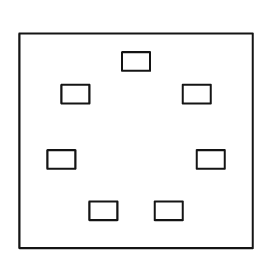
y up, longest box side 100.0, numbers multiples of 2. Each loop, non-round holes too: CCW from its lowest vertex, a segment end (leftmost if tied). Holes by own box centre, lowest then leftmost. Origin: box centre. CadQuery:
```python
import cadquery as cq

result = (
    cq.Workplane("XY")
    .moveTo(-50.0, -46.0)
    .lineTo(50.0, -46.0)
    .lineTo(50.0, 46.0)
    .lineTo(-50.0, 46.0)
    .close()
    .moveTo(-20.0, -34.0)
    .lineTo(-8.0, -34.0)
    .lineTo(-8.0, -26.0)
    .lineTo(-20.0, -26.0)
    .close()
    .moveTo(8.0, -34.0)
    .lineTo(20.0, -34.0)
    .lineTo(20.0, -26.0)
    .lineTo(8.0, -26.0)
    .close()
    .moveTo(-38.0, -12.0)
    .lineTo(-26.0, -12.0)
    .lineTo(-26.0, -4.0)
    .lineTo(-38.0, -4.0)
    .close()
    .moveTo(26.0, -12.0)
    .lineTo(38.0, -12.0)
    .lineTo(38.0, -4.0)
    .lineTo(26.0, -4.0)
    .close()
    .moveTo(-32.0, 16.0)
    .lineTo(-20.0, 16.0)
    .lineTo(-20.0, 24.0)
    .lineTo(-32.0, 24.0)
    .close()
    .moveTo(20.0, 16.0)
    .lineTo(32.0, 16.0)
    .lineTo(32.0, 24.0)
    .lineTo(20.0, 24.0)
    .close()
    .moveTo(-6.0, 30.0)
    .lineTo(6.0, 30.0)
    .lineTo(6.0, 38.0)
    .lineTo(-6.0, 38.0)
    .close()
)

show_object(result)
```